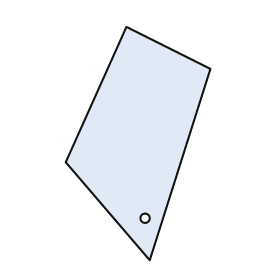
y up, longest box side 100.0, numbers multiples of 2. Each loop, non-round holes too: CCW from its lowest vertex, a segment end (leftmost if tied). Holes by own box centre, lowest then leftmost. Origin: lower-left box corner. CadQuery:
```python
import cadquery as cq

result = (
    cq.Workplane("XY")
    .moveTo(36.0, 0.0)
    .lineTo(62.0, 82.0)
    .lineTo(26.0, 100.0)
    .lineTo(0.0, 42.0)
    .close()
    .moveTo(34.0, 18.0)
    .circle(2.0)
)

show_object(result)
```